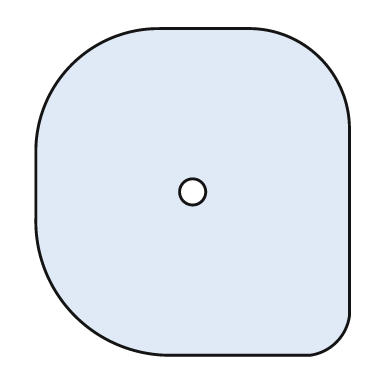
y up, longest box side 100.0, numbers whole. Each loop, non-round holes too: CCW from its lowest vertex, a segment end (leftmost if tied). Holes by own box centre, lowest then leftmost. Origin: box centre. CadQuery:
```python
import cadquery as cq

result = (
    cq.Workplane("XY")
    .moveTo(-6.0, -50.0)
    .lineTo(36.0, -50.0)
    .threePointArc((44.0, -46.0), (48.0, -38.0))
    .lineTo(48.0, 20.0)
    .threePointArc((39.0, 41.0), (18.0, 50.0))
    .lineTo(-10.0, 50.0)
    .threePointArc((-37.0, 39.0), (-48.0, 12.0))
    .lineTo(-48.0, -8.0)
    .threePointArc((-36.0, -38.0), (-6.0, -50.0))
    .close()
    .moveTo(0.0, 0.0)
    .circle(4.0)
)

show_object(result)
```